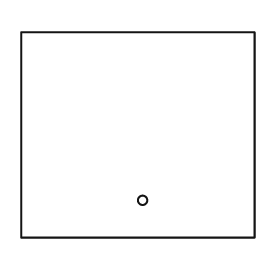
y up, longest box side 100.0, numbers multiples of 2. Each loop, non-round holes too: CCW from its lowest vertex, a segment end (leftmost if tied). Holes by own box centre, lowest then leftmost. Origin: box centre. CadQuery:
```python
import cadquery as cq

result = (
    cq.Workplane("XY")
    .moveTo(-50.0, -44.0)
    .lineTo(50.0, -44.0)
    .lineTo(50.0, 44.0)
    .lineTo(-50.0, 44.0)
    .close()
    .moveTo(2.0, -28.0)
    .circle(2.0)
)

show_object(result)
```